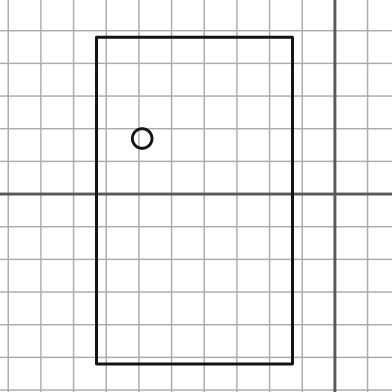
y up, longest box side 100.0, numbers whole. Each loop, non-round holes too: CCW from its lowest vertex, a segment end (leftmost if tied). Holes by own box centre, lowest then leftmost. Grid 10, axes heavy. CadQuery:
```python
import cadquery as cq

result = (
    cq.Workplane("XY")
    .moveTo(-73.0, -52.0)
    .lineTo(-13.0, -52.0)
    .lineTo(-13.0, 48.0)
    .lineTo(-73.0, 48.0)
    .close()
    .moveTo(-59.0, 17.0)
    .circle(3.0)
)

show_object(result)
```